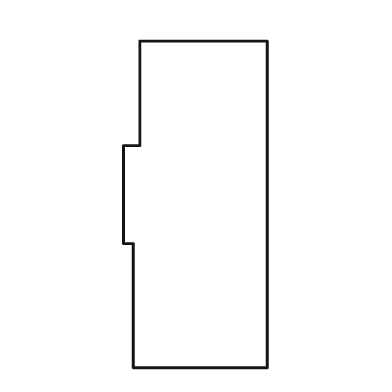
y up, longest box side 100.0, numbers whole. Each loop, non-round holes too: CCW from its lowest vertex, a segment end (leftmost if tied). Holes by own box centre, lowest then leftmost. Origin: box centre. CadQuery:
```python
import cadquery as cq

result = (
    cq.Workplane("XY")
    .moveTo(-19.0, -50.0)
    .lineTo(22.0, -50.0)
    .lineTo(22.0, 50.0)
    .lineTo(-17.0, 50.0)
    .lineTo(-17.0, 18.0)
    .lineTo(-22.0, 18.0)
    .lineTo(-22.0, -12.0)
    .lineTo(-19.0, -12.0)
    .close()
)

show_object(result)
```